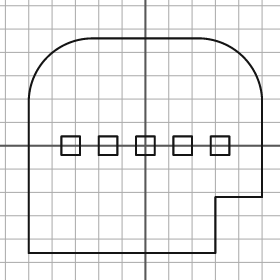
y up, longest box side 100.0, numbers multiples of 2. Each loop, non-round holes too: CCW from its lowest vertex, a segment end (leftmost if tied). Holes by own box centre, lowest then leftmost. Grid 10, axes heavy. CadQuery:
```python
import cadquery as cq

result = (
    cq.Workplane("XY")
    .moveTo(-50.0, -46.0)
    .lineTo(30.0, -46.0)
    .lineTo(30.0, -22.0)
    .lineTo(50.0, -22.0)
    .lineTo(50.0, 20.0)
    .threePointArc((42.0, 38.0), (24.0, 46.0))
    .lineTo(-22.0, 46.0)
    .threePointArc((-42.0, 38.0), (-50.0, 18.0))
    .close()
    .moveTo(-36.0, -4.0)
    .lineTo(-28.0, -4.0)
    .lineTo(-28.0, 4.0)
    .lineTo(-36.0, 4.0)
    .close()
    .moveTo(-20.0, -4.0)
    .lineTo(-12.0, -4.0)
    .lineTo(-12.0, 4.0)
    .lineTo(-20.0, 4.0)
    .close()
    .moveTo(-4.0, -4.0)
    .lineTo(4.0, -4.0)
    .lineTo(4.0, 4.0)
    .lineTo(-4.0, 4.0)
    .close()
    .moveTo(12.0, -4.0)
    .lineTo(20.0, -4.0)
    .lineTo(20.0, 4.0)
    .lineTo(12.0, 4.0)
    .close()
    .moveTo(28.0, -4.0)
    .lineTo(36.0, -4.0)
    .lineTo(36.0, 4.0)
    .lineTo(28.0, 4.0)
    .close()
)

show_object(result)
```